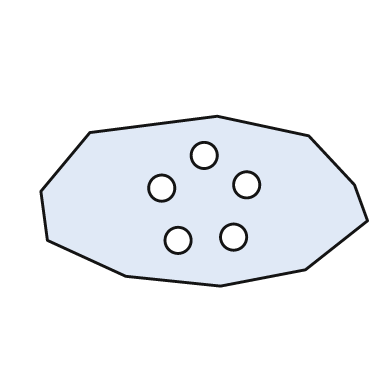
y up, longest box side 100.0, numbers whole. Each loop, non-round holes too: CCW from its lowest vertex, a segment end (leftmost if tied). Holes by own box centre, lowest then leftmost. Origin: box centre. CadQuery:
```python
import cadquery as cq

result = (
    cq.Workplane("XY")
    .moveTo(5.0, -26.0)
    .lineTo(31.0, -21.0)
    .lineTo(50.0, -6.0)
    .lineTo(46.0, 5.0)
    .lineTo(32.0, 20.0)
    .lineTo(4.0, 26.0)
    .lineTo(-35.0, 21.0)
    .lineTo(-50.0, 3.0)
    .lineTo(-48.0, -12.0)
    .lineTo(-24.0, -23.0)
    .close()
    .moveTo(-8.0, -12.0)
    .circle(4.0)
    .moveTo(9.0, -11.0)
    .circle(4.0)
    .moveTo(-13.0, 4.0)
    .circle(4.0)
    .moveTo(13.0, 5.0)
    .circle(4.0)
    .moveTo(0.0, 14.0)
    .circle(4.0)
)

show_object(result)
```